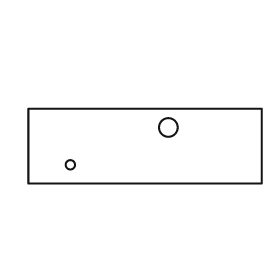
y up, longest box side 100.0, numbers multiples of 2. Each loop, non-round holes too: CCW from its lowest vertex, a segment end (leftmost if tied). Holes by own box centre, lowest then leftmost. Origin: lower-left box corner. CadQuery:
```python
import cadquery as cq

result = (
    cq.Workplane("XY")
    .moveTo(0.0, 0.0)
    .lineTo(100.0, 0.0)
    .lineTo(100.0, 32.0)
    .lineTo(0.0, 32.0)
    .close()
    .moveTo(18.0, 8.0)
    .circle(2.0)
    .moveTo(60.0, 24.0)
    .circle(4.0)
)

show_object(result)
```